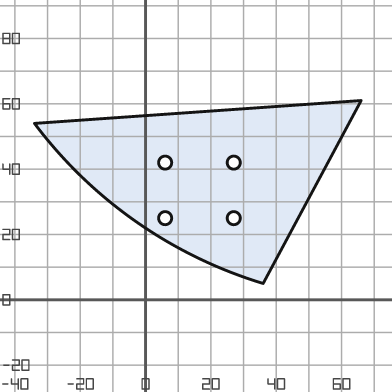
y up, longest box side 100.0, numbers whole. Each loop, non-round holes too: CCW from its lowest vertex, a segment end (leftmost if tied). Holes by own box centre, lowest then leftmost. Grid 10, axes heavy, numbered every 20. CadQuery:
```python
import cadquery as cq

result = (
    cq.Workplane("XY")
    .moveTo(36.0, 5.0)
    .lineTo(66.0, 61.0)
    .lineTo(-34.0, 54.0)
    .threePointArc((-3.0, 24.0), (36.0, 5.0))
    .close()
    .moveTo(6.0, 25.0)
    .circle(2.0)
    .moveTo(27.0, 25.0)
    .circle(2.0)
    .moveTo(6.0, 42.0)
    .circle(2.0)
    .moveTo(27.0, 42.0)
    .circle(2.0)
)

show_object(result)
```